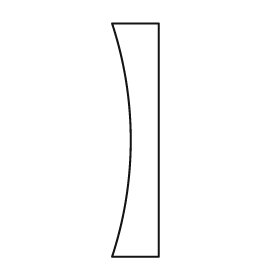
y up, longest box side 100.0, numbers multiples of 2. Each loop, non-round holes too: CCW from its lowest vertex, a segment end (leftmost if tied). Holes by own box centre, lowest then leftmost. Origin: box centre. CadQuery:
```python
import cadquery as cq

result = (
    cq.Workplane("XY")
    .moveTo(-10.0, -50.0)
    .lineTo(10.0, -50.0)
    .lineTo(10.0, 50.0)
    .lineTo(-10.0, 50.0)
    .threePointArc((-2.0, 0.0), (-10.0, -50.0))
    .close()
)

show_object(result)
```